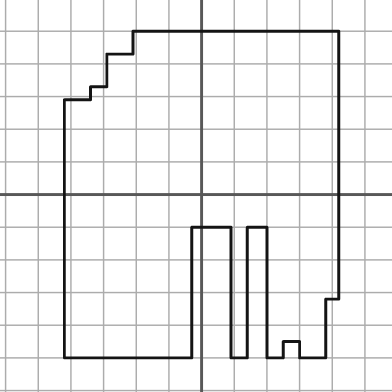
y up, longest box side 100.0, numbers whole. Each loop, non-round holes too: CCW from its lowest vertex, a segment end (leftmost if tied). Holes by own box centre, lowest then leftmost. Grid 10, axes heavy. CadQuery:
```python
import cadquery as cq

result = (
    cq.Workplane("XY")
    .moveTo(-42.0, -50.0)
    .lineTo(-3.0, -50.0)
    .lineTo(-3.0, -10.0)
    .lineTo(9.0, -10.0)
    .lineTo(9.0, -50.0)
    .lineTo(14.0, -50.0)
    .lineTo(14.0, -10.0)
    .lineTo(20.0, -10.0)
    .lineTo(20.0, -50.0)
    .lineTo(25.0, -50.0)
    .lineTo(25.0, -45.0)
    .lineTo(30.0, -45.0)
    .lineTo(30.0, -50.0)
    .lineTo(38.0, -50.0)
    .lineTo(38.0, -32.0)
    .lineTo(42.0, -32.0)
    .lineTo(42.0, 50.0)
    .lineTo(-21.0, 50.0)
    .lineTo(-21.0, 43.0)
    .lineTo(-29.0, 43.0)
    .lineTo(-29.0, 33.0)
    .lineTo(-34.0, 33.0)
    .lineTo(-34.0, 29.0)
    .lineTo(-42.0, 29.0)
    .close()
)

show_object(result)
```